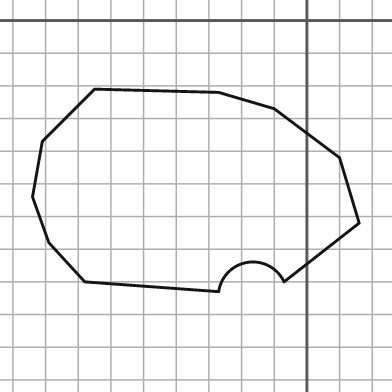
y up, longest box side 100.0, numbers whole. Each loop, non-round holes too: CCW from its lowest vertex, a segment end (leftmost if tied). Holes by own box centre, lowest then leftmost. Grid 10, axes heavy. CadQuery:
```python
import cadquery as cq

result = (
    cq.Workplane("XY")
    .moveTo(-27.0, -83.0)
    .threePointArc((-18.0, -74.0), (-7.0, -80.0))
    .lineTo(16.0, -62.0)
    .lineTo(10.0, -42.0)
    .lineTo(-10.0, -27.0)
    .lineTo(-27.0, -22.0)
    .lineTo(-65.0, -21.0)
    .lineTo(-81.0, -37.0)
    .lineTo(-84.0, -54.0)
    .lineTo(-79.0, -68.0)
    .lineTo(-68.0, -80.0)
    .close()
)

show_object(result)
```